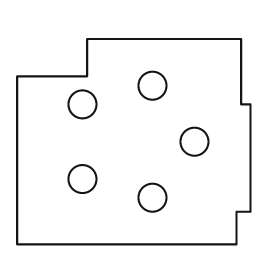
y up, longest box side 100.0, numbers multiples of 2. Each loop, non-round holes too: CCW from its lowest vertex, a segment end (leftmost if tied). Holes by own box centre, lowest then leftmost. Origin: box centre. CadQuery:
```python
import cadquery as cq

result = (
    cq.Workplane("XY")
    .moveTo(-50.0, -44.0)
    .lineTo(44.0, -44.0)
    .lineTo(44.0, -30.0)
    .lineTo(50.0, -30.0)
    .lineTo(50.0, 16.0)
    .lineTo(46.0, 16.0)
    .lineTo(46.0, 44.0)
    .lineTo(-20.0, 44.0)
    .lineTo(-20.0, 28.0)
    .lineTo(-50.0, 28.0)
    .close()
    .moveTo(8.0, -24.0)
    .circle(6.0)
    .moveTo(-22.0, -16.0)
    .circle(6.0)
    .moveTo(26.0, 0.0)
    .circle(6.0)
    .moveTo(-22.0, 16.0)
    .circle(6.0)
    .moveTo(8.0, 24.0)
    .circle(6.0)
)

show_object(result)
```